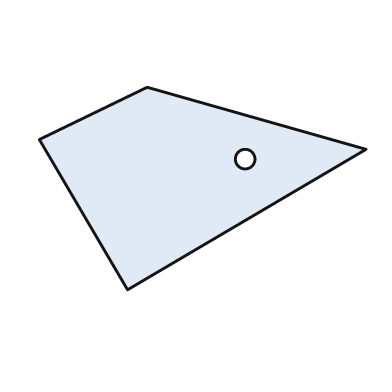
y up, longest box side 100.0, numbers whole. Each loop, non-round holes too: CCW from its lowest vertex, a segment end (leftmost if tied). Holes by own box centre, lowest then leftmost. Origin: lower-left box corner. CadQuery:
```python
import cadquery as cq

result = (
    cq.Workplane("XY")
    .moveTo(27.0, 0.0)
    .lineTo(100.0, 43.0)
    .lineTo(33.0, 62.0)
    .lineTo(0.0, 46.0)
    .close()
    .moveTo(63.0, 40.0)
    .circle(3.0)
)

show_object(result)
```